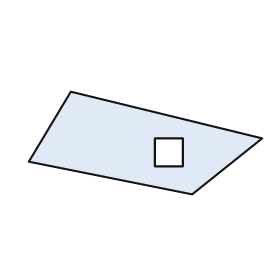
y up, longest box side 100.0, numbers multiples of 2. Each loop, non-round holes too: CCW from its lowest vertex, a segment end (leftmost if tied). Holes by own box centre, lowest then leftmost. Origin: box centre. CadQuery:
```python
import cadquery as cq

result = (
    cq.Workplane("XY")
    .moveTo(20.0, -22.0)
    .lineTo(50.0, 2.0)
    .lineTo(-32.0, 22.0)
    .lineTo(-50.0, -8.0)
    .close()
    .moveTo(4.0, -10.0)
    .lineTo(16.0, -10.0)
    .lineTo(16.0, 2.0)
    .lineTo(4.0, 2.0)
    .close()
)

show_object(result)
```